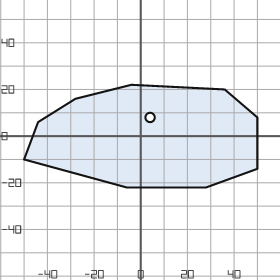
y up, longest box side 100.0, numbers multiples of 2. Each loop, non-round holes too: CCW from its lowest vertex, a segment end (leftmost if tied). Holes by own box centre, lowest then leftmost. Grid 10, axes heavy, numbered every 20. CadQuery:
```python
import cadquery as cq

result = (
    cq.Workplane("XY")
    .moveTo(-6.0, -22.0)
    .lineTo(28.0, -22.0)
    .lineTo(50.0, -14.0)
    .lineTo(50.0, 8.0)
    .lineTo(36.0, 20.0)
    .lineTo(-4.0, 22.0)
    .lineTo(-28.0, 16.0)
    .lineTo(-44.0, 6.0)
    .lineTo(-50.0, -10.0)
    .close()
    .moveTo(4.0, 8.0)
    .circle(2.0)
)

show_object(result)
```